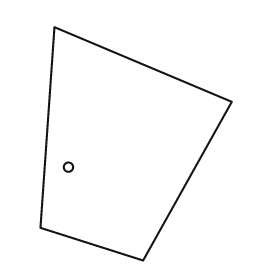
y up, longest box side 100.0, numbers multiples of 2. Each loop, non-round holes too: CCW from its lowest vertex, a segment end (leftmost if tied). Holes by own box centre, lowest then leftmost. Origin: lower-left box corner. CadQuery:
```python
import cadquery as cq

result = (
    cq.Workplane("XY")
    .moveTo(44.0, 0.0)
    .lineTo(82.0, 68.0)
    .lineTo(6.0, 100.0)
    .lineTo(0.0, 14.0)
    .close()
    .moveTo(12.0, 40.0)
    .circle(2.0)
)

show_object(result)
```